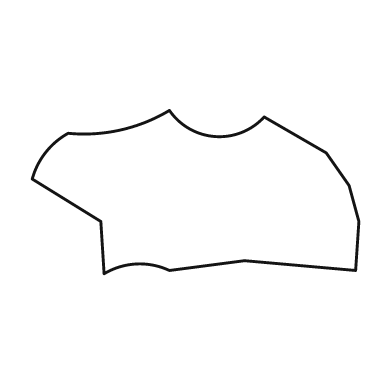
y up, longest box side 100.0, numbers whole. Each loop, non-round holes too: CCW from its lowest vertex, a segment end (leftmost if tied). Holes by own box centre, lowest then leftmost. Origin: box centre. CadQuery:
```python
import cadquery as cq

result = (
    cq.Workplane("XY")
    .moveTo(-28.0, -25.0)
    .threePointArc((-18.0, -22.0), (-8.0, -24.0))
    .lineTo(15.0, -21.0)
    .lineTo(49.0, -24.0)
    .lineTo(50.0, -9.0)
    .lineTo(47.0, 2.0)
    .lineTo(40.0, 12.0)
    .lineTo(21.0, 23.0)
    .threePointArc((6.0, 17.0), (-8.0, 25.0))
    .threePointArc((-23.0, 19.0), (-39.0, 18.0))
    .threePointArc((-46.0, 12.0), (-50.0, 4.0))
    .lineTo(-29.0, -9.0)
    .close()
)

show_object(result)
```